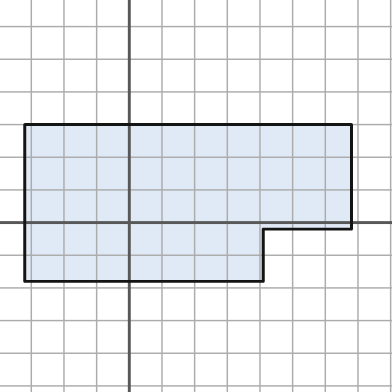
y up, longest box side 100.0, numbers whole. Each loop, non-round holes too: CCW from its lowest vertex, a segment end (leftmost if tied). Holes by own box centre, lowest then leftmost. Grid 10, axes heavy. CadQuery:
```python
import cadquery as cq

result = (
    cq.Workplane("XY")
    .moveTo(-32.0, -18.0)
    .lineTo(41.0, -18.0)
    .lineTo(41.0, -2.0)
    .lineTo(68.0, -2.0)
    .lineTo(68.0, 30.0)
    .lineTo(-32.0, 30.0)
    .close()
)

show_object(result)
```